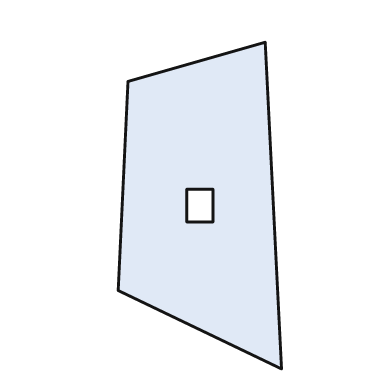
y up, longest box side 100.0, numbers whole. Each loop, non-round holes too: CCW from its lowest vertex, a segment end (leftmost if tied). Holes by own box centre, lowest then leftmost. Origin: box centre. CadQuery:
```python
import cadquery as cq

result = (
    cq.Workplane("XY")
    .moveTo(25.0, -50.0)
    .lineTo(20.0, 50.0)
    .lineTo(-22.0, 38.0)
    .lineTo(-25.0, -26.0)
    .close()
    .moveTo(-4.0, -5.0)
    .lineTo(4.0, -5.0)
    .lineTo(4.0, 5.0)
    .lineTo(-4.0, 5.0)
    .close()
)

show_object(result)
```